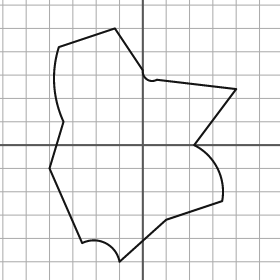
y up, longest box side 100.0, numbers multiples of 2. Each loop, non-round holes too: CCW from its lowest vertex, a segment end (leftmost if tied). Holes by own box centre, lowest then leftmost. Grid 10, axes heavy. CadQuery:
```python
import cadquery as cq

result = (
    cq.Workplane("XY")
    .moveTo(-10.0, -50.0)
    .lineTo(10.0, -32.0)
    .lineTo(34.0, -24.0)
    .threePointArc((32.0, -10.0), (22.0, 0.0))
    .lineTo(40.0, 24.0)
    .lineTo(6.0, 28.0)
    .threePointArc((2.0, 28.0), (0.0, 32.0))
    .lineTo(-12.0, 50.0)
    .lineTo(-36.0, 42.0)
    .threePointArc((-38.0, 26.0), (-34.0, 10.0))
    .lineTo(-40.0, -10.0)
    .lineTo(-26.0, -42.0)
    .threePointArc((-16.0, -42.0), (-10.0, -50.0))
    .close()
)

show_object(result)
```